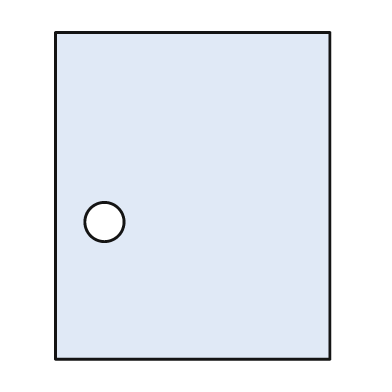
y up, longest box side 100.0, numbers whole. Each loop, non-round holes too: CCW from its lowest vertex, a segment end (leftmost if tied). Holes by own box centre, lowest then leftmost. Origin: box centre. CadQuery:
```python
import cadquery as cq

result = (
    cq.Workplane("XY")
    .moveTo(-42.0, -50.0)
    .lineTo(42.0, -50.0)
    .lineTo(42.0, 50.0)
    .lineTo(-42.0, 50.0)
    .close()
    .moveTo(-27.0, -8.0)
    .circle(6.0)
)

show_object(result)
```